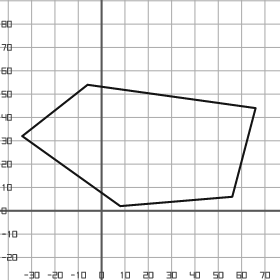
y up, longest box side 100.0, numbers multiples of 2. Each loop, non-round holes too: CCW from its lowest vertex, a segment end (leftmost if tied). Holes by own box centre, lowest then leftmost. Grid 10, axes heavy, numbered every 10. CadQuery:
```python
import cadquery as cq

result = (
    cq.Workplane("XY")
    .moveTo(8.0, 2.0)
    .lineTo(56.0, 6.0)
    .lineTo(66.0, 44.0)
    .lineTo(-6.0, 54.0)
    .lineTo(-34.0, 32.0)
    .close()
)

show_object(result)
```